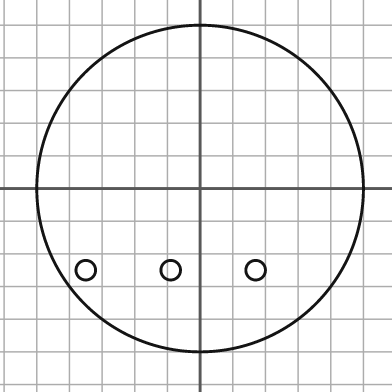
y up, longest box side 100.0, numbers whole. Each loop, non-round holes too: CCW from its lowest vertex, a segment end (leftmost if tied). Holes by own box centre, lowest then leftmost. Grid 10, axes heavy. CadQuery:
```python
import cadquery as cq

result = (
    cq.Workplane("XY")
    .moveTo(0.0, 0.0)
    .circle(50.0)
    .moveTo(-35.0, -25.0)
    .circle(3.0)
    .moveTo(-9.0, -25.0)
    .circle(3.0)
    .moveTo(17.0, -25.0)
    .circle(3.0)
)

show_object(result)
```